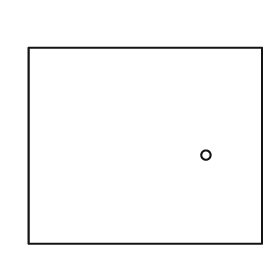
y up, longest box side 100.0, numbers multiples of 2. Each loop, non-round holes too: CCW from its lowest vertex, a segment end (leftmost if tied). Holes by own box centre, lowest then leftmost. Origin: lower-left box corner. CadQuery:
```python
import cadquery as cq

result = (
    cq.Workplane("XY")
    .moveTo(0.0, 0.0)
    .lineTo(100.0, 0.0)
    .lineTo(100.0, 84.0)
    .lineTo(0.0, 84.0)
    .close()
    .moveTo(76.0, 38.0)
    .circle(2.0)
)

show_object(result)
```